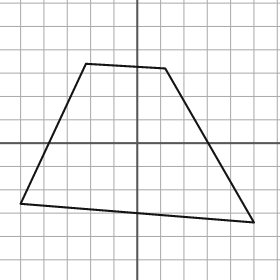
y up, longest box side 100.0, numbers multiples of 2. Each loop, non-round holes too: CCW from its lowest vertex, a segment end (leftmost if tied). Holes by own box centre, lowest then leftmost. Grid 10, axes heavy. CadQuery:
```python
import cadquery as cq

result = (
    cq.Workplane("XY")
    .moveTo(50.0, -34.0)
    .lineTo(12.0, 32.0)
    .lineTo(-22.0, 34.0)
    .lineTo(-50.0, -26.0)
    .close()
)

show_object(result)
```